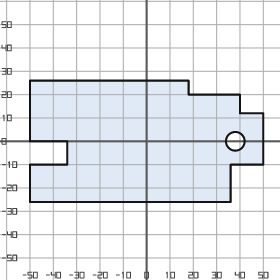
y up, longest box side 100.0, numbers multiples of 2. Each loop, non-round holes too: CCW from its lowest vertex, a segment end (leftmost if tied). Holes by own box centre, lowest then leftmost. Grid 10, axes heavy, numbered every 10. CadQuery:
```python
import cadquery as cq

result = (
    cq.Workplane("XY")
    .moveTo(-50.0, -26.0)
    .lineTo(36.0, -26.0)
    .lineTo(36.0, -10.0)
    .lineTo(50.0, -10.0)
    .lineTo(50.0, 12.0)
    .lineTo(40.0, 12.0)
    .lineTo(40.0, 20.0)
    .lineTo(18.0, 20.0)
    .lineTo(18.0, 26.0)
    .lineTo(-50.0, 26.0)
    .lineTo(-50.0, 0.0)
    .lineTo(-34.0, 0.0)
    .lineTo(-34.0, -10.0)
    .lineTo(-50.0, -10.0)
    .close()
    .moveTo(38.0, 0.0)
    .circle(4.0)
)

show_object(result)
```